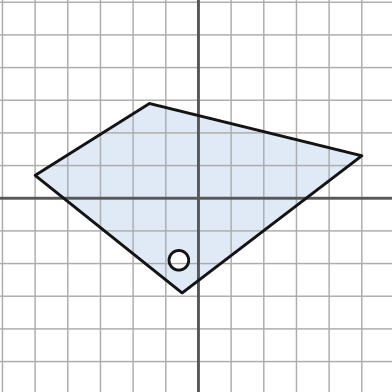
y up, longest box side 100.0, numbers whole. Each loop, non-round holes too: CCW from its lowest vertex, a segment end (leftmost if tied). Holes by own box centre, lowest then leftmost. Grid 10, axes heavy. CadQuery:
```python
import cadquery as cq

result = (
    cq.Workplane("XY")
    .moveTo(-5.0, -29.0)
    .lineTo(50.0, 13.0)
    .lineTo(-15.0, 29.0)
    .lineTo(-50.0, 7.0)
    .close()
    .moveTo(-6.0, -19.0)
    .circle(3.0)
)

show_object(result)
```